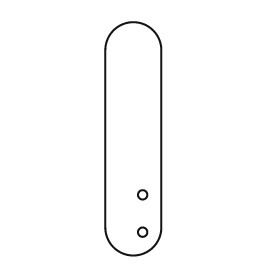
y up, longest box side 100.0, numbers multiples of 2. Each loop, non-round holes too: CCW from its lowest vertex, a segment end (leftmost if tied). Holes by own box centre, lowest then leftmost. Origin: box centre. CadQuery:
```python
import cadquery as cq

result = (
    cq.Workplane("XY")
    .moveTo(-12.0, -38.0)
    .threePointArc((0.0, -50.0), (12.0, -38.0))
    .lineTo(12.0, 38.0)
    .threePointArc((0.0, 50.0), (-12.0, 38.0))
    .close()
    .moveTo(4.0, -40.0)
    .circle(2.0)
    .moveTo(4.0, -24.0)
    .circle(2.0)
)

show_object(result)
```